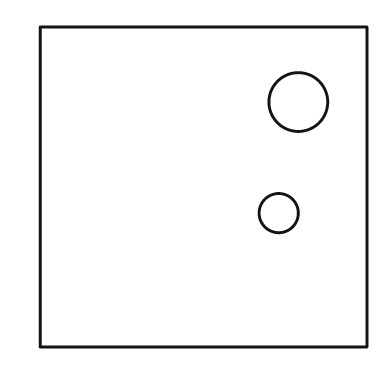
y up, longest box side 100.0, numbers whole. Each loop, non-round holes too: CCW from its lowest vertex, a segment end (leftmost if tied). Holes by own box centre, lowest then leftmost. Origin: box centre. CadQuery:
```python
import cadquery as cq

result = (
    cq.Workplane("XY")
    .moveTo(-50.0, -49.0)
    .lineTo(50.0, -49.0)
    .lineTo(50.0, 49.0)
    .lineTo(-50.0, 49.0)
    .close()
    .moveTo(23.0, -8.0)
    .circle(6.0)
    .moveTo(29.0, 26.0)
    .circle(9.0)
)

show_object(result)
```